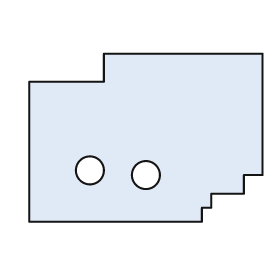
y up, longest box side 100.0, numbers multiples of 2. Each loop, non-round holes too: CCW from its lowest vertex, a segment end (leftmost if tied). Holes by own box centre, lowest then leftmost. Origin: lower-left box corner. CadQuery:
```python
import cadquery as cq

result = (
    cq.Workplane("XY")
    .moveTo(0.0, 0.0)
    .lineTo(74.0, 0.0)
    .lineTo(74.0, 6.0)
    .lineTo(78.0, 6.0)
    .lineTo(78.0, 12.0)
    .lineTo(92.0, 12.0)
    .lineTo(92.0, 20.0)
    .lineTo(100.0, 20.0)
    .lineTo(100.0, 72.0)
    .lineTo(32.0, 72.0)
    .lineTo(32.0, 60.0)
    .lineTo(0.0, 60.0)
    .close()
    .moveTo(50.0, 20.0)
    .circle(6.0)
    .moveTo(26.0, 22.0)
    .circle(6.0)
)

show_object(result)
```